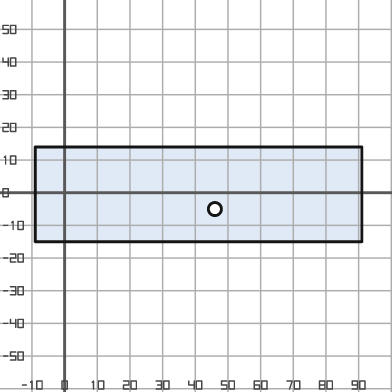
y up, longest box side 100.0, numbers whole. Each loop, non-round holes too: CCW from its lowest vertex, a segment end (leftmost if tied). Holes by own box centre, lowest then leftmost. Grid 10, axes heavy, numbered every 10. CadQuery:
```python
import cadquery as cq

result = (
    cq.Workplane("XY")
    .moveTo(-9.0, -15.0)
    .lineTo(91.0, -15.0)
    .lineTo(91.0, 14.0)
    .lineTo(-9.0, 14.0)
    .close()
    .moveTo(46.0, -5.0)
    .circle(2.0)
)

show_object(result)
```